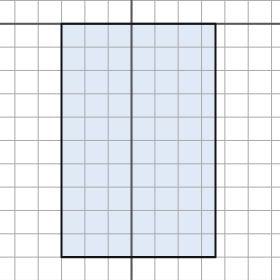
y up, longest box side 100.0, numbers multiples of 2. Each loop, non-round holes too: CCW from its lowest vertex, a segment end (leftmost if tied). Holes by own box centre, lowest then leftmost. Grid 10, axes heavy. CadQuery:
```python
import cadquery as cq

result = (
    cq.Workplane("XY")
    .moveTo(-30.0, -100.0)
    .lineTo(36.0, -100.0)
    .lineTo(36.0, 0.0)
    .lineTo(-30.0, 0.0)
    .close()
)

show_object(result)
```